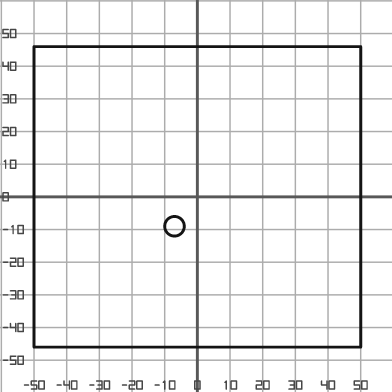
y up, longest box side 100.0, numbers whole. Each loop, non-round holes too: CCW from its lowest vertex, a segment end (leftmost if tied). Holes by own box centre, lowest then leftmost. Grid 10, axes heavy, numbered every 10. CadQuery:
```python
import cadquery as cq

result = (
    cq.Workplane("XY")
    .moveTo(-50.0, -46.0)
    .lineTo(50.0, -46.0)
    .lineTo(50.0, 46.0)
    .lineTo(-50.0, 46.0)
    .close()
    .moveTo(-7.0, -9.0)
    .circle(3.0)
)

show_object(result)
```